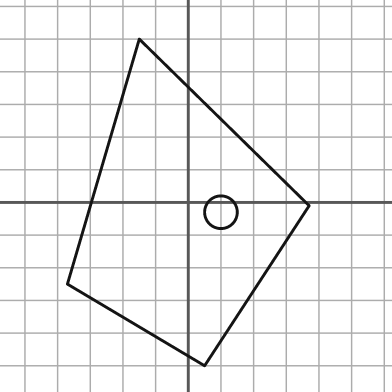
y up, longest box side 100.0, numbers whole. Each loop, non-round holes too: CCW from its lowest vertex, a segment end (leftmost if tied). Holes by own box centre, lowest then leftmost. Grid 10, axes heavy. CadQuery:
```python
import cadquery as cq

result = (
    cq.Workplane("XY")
    .moveTo(5.0, -50.0)
    .lineTo(37.0, -1.0)
    .lineTo(-15.0, 50.0)
    .lineTo(-37.0, -25.0)
    .close()
    .moveTo(10.0, -3.0)
    .circle(5.0)
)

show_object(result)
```